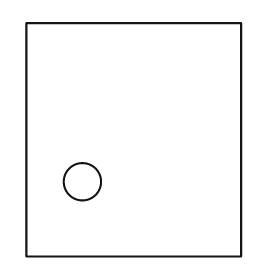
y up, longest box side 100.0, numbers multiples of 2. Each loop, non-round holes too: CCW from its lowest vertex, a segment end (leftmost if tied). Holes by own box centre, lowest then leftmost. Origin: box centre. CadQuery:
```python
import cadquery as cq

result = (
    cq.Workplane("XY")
    .moveTo(-46.0, -50.0)
    .lineTo(46.0, -50.0)
    .lineTo(46.0, 50.0)
    .lineTo(-46.0, 50.0)
    .close()
    .moveTo(-22.0, -18.0)
    .circle(8.0)
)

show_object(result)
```